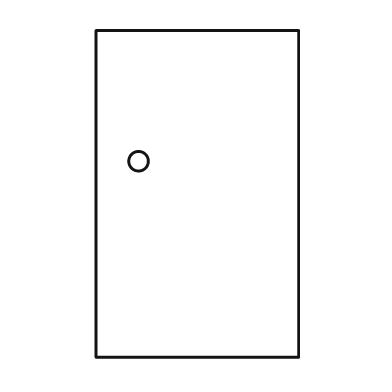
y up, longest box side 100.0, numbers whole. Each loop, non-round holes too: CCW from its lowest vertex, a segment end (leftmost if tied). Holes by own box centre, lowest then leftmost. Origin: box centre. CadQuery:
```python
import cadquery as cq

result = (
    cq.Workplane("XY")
    .moveTo(-31.0, -50.0)
    .lineTo(31.0, -50.0)
    .lineTo(31.0, 50.0)
    .lineTo(-31.0, 50.0)
    .close()
    .moveTo(-18.0, 10.0)
    .circle(3.0)
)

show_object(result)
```